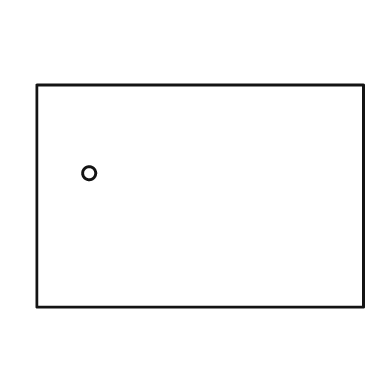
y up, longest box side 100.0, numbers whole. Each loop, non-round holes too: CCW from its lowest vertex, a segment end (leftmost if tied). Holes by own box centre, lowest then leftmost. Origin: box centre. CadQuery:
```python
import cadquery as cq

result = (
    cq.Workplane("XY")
    .moveTo(-50.0, -34.0)
    .lineTo(50.0, -34.0)
    .lineTo(50.0, 34.0)
    .lineTo(-50.0, 34.0)
    .close()
    .moveTo(-34.0, 7.0)
    .circle(2.0)
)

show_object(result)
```